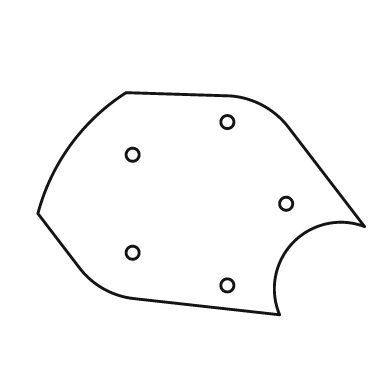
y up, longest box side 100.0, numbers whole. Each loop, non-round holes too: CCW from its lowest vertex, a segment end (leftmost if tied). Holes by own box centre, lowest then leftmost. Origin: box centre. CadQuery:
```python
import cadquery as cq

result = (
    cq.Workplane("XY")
    .moveTo(24.0, -34.0)
    .threePointArc((28.0, -12.0), (50.0, -7.0))
    .lineTo(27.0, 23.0)
    .threePointArc((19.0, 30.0), (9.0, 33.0))
    .lineTo(-23.0, 34.0)
    .threePointArc((-40.0, 18.0), (-50.0, -3.0))
    .lineTo(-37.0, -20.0)
    .threePointArc((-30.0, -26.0), (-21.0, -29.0))
    .close()
    .moveTo(8.0, -25.0)
    .circle(2.0)
    .moveTo(-21.0, -15.0)
    .circle(2.0)
    .moveTo(26.0, 0.0)
    .circle(2.0)
    .moveTo(-21.0, 15.0)
    .circle(2.0)
    .moveTo(8.0, 25.0)
    .circle(2.0)
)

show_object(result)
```